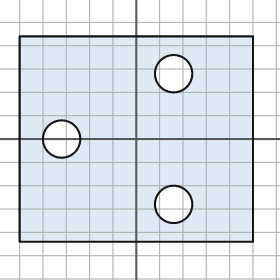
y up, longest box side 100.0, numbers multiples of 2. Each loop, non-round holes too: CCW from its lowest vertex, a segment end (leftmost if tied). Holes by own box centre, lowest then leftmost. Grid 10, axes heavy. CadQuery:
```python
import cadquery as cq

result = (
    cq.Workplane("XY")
    .moveTo(-50.0, -44.0)
    .lineTo(50.0, -44.0)
    .lineTo(50.0, 44.0)
    .lineTo(-50.0, 44.0)
    .close()
    .moveTo(16.0, -28.0)
    .circle(8.0)
    .moveTo(-32.0, 0.0)
    .circle(8.0)
    .moveTo(16.0, 28.0)
    .circle(8.0)
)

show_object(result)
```